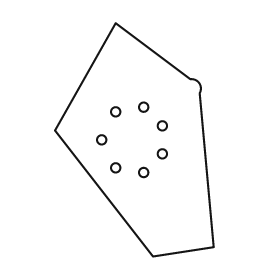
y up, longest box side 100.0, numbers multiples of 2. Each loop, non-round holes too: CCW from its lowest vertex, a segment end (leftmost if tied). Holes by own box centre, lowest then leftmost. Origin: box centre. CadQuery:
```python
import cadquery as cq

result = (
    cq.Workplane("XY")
    .moveTo(8.0, -50.0)
    .lineTo(34.0, -46.0)
    .lineTo(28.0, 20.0)
    .threePointArc((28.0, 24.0), (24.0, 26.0))
    .lineTo(-8.0, 50.0)
    .lineTo(-34.0, 4.0)
    .close()
    .moveTo(4.0, -14.0)
    .circle(2.0)
    .moveTo(-8.0, -12.0)
    .circle(2.0)
    .moveTo(12.0, -6.0)
    .circle(2.0)
    .moveTo(-14.0, 0.0)
    .circle(2.0)
    .moveTo(12.0, 6.0)
    .circle(2.0)
    .moveTo(-8.0, 12.0)
    .circle(2.0)
    .moveTo(4.0, 14.0)
    .circle(2.0)
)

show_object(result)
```